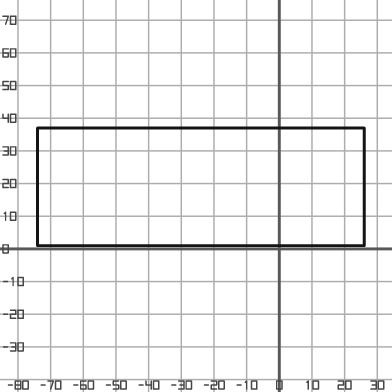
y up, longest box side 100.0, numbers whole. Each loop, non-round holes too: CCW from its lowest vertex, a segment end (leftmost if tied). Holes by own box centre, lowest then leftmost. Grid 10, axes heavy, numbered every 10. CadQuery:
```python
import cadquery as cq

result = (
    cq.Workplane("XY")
    .moveTo(-74.0, 1.0)
    .lineTo(26.0, 1.0)
    .lineTo(26.0, 37.0)
    .lineTo(-74.0, 37.0)
    .close()
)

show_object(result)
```